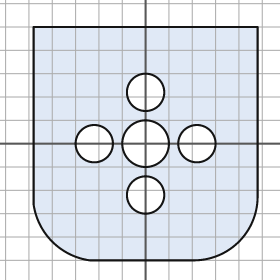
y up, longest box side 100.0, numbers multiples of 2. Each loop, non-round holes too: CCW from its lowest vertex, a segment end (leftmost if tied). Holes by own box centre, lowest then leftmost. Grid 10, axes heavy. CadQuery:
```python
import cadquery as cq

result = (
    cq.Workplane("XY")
    .moveTo(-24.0, -50.0)
    .lineTo(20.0, -50.0)
    .threePointArc((40.0, -42.0), (48.0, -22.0))
    .lineTo(48.0, 50.0)
    .lineTo(-48.0, 50.0)
    .lineTo(-48.0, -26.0)
    .threePointArc((-40.0, -42.0), (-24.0, -50.0))
    .close()
    .moveTo(0.0, -22.0)
    .circle(8.0)
    .moveTo(-22.0, 0.0)
    .circle(8.0)
    .moveTo(0.0, 0.0)
    .circle(10.0)
    .moveTo(22.0, 0.0)
    .circle(8.0)
    .moveTo(0.0, 22.0)
    .circle(8.0)
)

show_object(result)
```